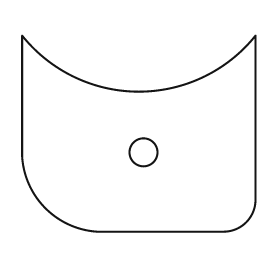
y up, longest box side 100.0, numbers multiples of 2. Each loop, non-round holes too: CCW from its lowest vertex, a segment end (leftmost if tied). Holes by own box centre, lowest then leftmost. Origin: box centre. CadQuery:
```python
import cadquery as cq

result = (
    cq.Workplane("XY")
    .moveTo(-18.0, -42.0)
    .lineTo(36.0, -42.0)
    .threePointArc((46.0, -38.0), (50.0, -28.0))
    .lineTo(50.0, 42.0)
    .threePointArc((0.0, 18.0), (-50.0, 42.0))
    .lineTo(-50.0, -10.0)
    .threePointArc((-40.0, -32.0), (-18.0, -42.0))
    .close()
    .moveTo(2.0, -8.0)
    .circle(6.0)
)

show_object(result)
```